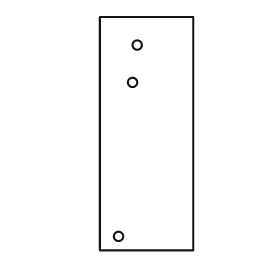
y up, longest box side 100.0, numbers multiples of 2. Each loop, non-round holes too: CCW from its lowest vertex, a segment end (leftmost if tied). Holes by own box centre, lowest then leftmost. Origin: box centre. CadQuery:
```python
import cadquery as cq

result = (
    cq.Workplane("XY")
    .moveTo(-20.0, -50.0)
    .lineTo(20.0, -50.0)
    .lineTo(20.0, 50.0)
    .lineTo(-20.0, 50.0)
    .close()
    .moveTo(-12.0, -44.0)
    .circle(2.0)
    .moveTo(-6.0, 22.0)
    .circle(2.0)
    .moveTo(-4.0, 38.0)
    .circle(2.0)
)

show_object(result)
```